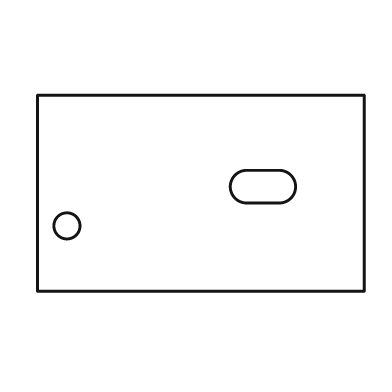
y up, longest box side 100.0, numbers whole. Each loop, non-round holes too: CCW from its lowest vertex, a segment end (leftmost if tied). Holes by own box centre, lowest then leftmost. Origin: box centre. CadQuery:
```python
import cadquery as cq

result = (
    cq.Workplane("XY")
    .moveTo(-50.0, -30.0)
    .lineTo(50.0, -30.0)
    .lineTo(50.0, 30.0)
    .lineTo(-50.0, 30.0)
    .close()
    .moveTo(-41.0, -10.0)
    .circle(4.0)
    .moveTo(14.0, -3.0)
    .lineTo(24.0, -3.0)
    .threePointArc((29.0, 2.0), (24.0, 7.0))
    .lineTo(14.0, 7.0)
    .threePointArc((9.0, 2.0), (14.0, -3.0))
    .close()
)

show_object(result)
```